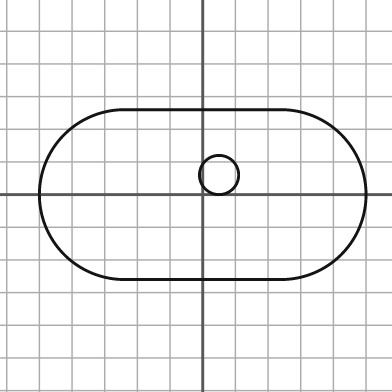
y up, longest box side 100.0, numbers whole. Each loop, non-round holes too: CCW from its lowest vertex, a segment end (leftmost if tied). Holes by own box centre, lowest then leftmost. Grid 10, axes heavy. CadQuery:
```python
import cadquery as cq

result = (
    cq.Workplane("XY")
    .moveTo(-24.0, -26.0)
    .lineTo(24.0, -26.0)
    .threePointArc((50.0, 0.0), (24.0, 26.0))
    .lineTo(-24.0, 26.0)
    .threePointArc((-50.0, 0.0), (-24.0, -26.0))
    .close()
    .moveTo(5.0, 6.0)
    .circle(6.0)
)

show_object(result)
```